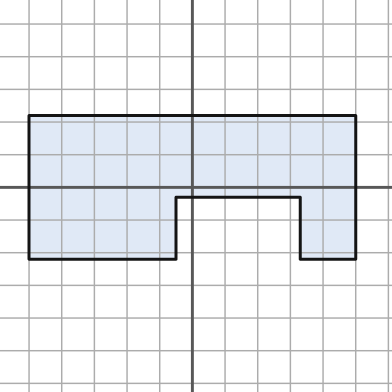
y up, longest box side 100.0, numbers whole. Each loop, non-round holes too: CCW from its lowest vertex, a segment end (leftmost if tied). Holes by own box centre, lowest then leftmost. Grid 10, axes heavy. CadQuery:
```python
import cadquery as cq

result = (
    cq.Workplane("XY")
    .moveTo(-50.0, -22.0)
    .lineTo(-5.0, -22.0)
    .lineTo(-5.0, -3.0)
    .lineTo(33.0, -3.0)
    .lineTo(33.0, -22.0)
    .lineTo(50.0, -22.0)
    .lineTo(50.0, 22.0)
    .lineTo(-50.0, 22.0)
    .close()
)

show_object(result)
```